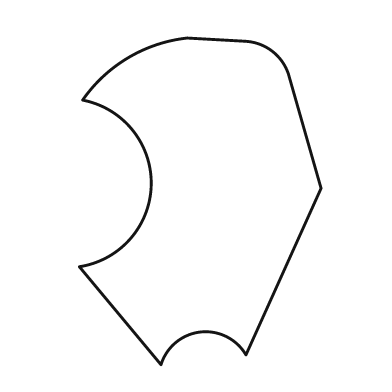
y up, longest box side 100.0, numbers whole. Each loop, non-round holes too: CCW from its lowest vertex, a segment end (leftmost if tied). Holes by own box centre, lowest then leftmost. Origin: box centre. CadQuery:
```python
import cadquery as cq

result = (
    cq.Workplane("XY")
    .moveTo(-12.0, -50.0)
    .threePointArc((0.0, -40.0), (14.0, -47.0))
    .lineTo(37.0, 4.0)
    .lineTo(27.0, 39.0)
    .threePointArc((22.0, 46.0), (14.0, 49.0))
    .lineTo(-4.0, 50.0)
    .threePointArc((-22.0, 44.0), (-36.0, 31.0))
    .threePointArc((-15.0, 5.0), (-37.0, -20.0))
    .close()
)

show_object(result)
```